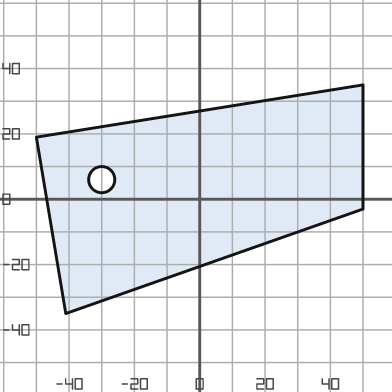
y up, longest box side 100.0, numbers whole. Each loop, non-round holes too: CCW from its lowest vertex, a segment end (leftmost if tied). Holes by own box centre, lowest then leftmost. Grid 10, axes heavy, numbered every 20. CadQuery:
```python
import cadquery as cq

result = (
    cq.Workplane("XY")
    .moveTo(-41.0, -35.0)
    .lineTo(50.0, -3.0)
    .lineTo(50.0, 35.0)
    .lineTo(-50.0, 19.0)
    .close()
    .moveTo(-30.0, 6.0)
    .circle(4.0)
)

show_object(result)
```